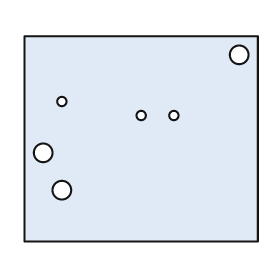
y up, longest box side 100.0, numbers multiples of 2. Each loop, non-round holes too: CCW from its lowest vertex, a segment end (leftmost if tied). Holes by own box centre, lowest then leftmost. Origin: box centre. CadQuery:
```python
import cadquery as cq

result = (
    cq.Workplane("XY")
    .moveTo(-50.0, -44.0)
    .lineTo(50.0, -44.0)
    .lineTo(50.0, 44.0)
    .lineTo(-50.0, 44.0)
    .close()
    .moveTo(-34.0, -22.0)
    .circle(4.0)
    .moveTo(-42.0, -6.0)
    .circle(4.0)
    .moveTo(0.0, 10.0)
    .circle(2.0)
    .moveTo(14.0, 10.0)
    .circle(2.0)
    .moveTo(-34.0, 16.0)
    .circle(2.0)
    .moveTo(42.0, 36.0)
    .circle(4.0)
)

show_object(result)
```